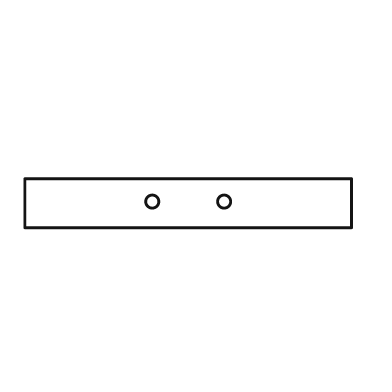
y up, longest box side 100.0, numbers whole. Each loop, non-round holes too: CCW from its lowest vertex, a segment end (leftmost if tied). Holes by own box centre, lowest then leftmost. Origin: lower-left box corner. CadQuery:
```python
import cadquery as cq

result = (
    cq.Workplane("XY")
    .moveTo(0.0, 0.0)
    .lineTo(100.0, 0.0)
    .lineTo(100.0, 15.0)
    .lineTo(0.0, 15.0)
    .close()
    .moveTo(39.0, 8.0)
    .circle(2.0)
    .moveTo(61.0, 8.0)
    .circle(2.0)
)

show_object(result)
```